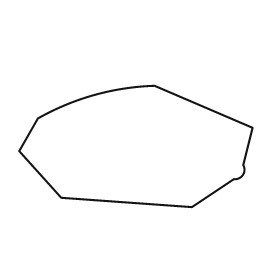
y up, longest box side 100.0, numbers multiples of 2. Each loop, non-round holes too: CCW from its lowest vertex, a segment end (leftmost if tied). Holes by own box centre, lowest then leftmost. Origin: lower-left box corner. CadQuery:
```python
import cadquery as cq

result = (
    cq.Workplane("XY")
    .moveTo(74.0, 0.0)
    .lineTo(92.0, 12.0)
    .threePointArc((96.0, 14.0), (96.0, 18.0))
    .lineTo(100.0, 34.0)
    .lineTo(58.0, 52.0)
    .threePointArc((32.0, 48.0), (8.0, 38.0))
    .lineTo(0.0, 24.0)
    .lineTo(18.0, 4.0)
    .close()
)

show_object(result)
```